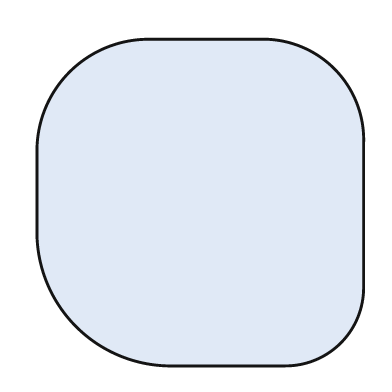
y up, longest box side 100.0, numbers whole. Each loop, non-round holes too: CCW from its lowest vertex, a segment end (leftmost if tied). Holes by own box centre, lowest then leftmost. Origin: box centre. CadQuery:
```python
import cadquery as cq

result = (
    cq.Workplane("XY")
    .moveTo(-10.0, -50.0)
    .lineTo(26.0, -50.0)
    .threePointArc((43.0, -43.0), (50.0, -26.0))
    .lineTo(50.0, 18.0)
    .threePointArc((41.0, 41.0), (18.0, 50.0))
    .lineTo(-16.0, 50.0)
    .threePointArc((-40.0, 40.0), (-50.0, 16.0))
    .lineTo(-50.0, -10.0)
    .threePointArc((-38.0, -38.0), (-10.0, -50.0))
    .close()
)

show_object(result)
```